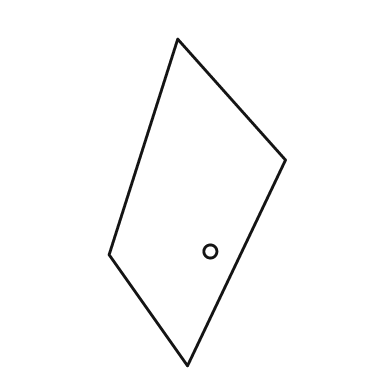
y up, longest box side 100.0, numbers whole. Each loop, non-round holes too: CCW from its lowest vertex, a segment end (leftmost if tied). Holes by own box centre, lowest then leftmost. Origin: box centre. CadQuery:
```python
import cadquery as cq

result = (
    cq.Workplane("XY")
    .moveTo(-3.0, -50.0)
    .lineTo(27.0, 13.0)
    .lineTo(-6.0, 50.0)
    .lineTo(-27.0, -16.0)
    .close()
    .moveTo(4.0, -15.0)
    .circle(2.0)
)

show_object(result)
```